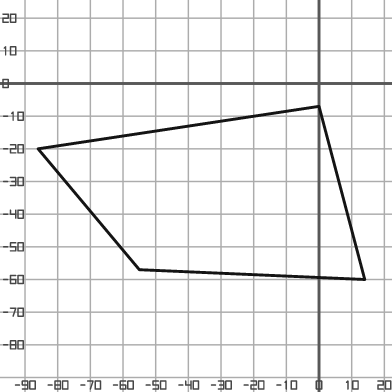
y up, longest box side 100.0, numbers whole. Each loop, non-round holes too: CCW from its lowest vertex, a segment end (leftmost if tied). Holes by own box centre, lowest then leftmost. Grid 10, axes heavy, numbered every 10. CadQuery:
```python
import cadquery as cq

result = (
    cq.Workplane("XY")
    .moveTo(14.0, -60.0)
    .lineTo(0.0, -7.0)
    .lineTo(-86.0, -20.0)
    .lineTo(-55.0, -57.0)
    .close()
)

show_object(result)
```